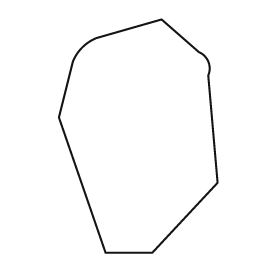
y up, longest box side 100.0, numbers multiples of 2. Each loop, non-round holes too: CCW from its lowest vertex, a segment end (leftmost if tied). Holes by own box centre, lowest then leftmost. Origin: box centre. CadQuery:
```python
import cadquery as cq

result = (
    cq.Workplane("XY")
    .moveTo(-14.0, -50.0)
    .lineTo(6.0, -50.0)
    .lineTo(34.0, -20.0)
    .lineTo(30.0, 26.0)
    .threePointArc((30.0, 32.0), (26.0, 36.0))
    .lineTo(10.0, 50.0)
    .lineTo(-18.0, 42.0)
    .threePointArc((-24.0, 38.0), (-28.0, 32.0))
    .lineTo(-34.0, 8.0)
    .close()
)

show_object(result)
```